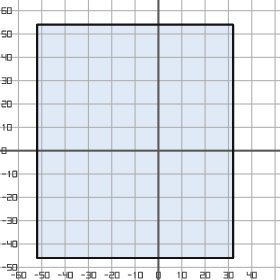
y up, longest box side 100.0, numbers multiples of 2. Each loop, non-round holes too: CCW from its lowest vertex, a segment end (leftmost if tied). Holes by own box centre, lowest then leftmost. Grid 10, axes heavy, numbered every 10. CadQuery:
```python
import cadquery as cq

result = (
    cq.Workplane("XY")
    .moveTo(-52.0, -46.0)
    .lineTo(32.0, -46.0)
    .lineTo(32.0, 54.0)
    .lineTo(-52.0, 54.0)
    .close()
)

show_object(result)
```